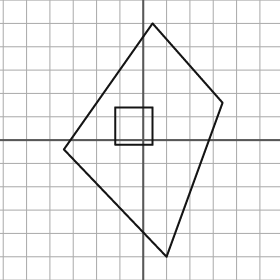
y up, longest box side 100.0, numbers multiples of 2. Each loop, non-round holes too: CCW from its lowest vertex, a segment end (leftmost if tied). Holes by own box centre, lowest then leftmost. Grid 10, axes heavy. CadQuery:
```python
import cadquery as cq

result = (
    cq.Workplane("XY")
    .moveTo(10.0, -50.0)
    .lineTo(34.0, 16.0)
    .lineTo(4.0, 50.0)
    .lineTo(-34.0, -4.0)
    .close()
    .moveTo(-12.0, -2.0)
    .lineTo(4.0, -2.0)
    .lineTo(4.0, 14.0)
    .lineTo(-12.0, 14.0)
    .close()
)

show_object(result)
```